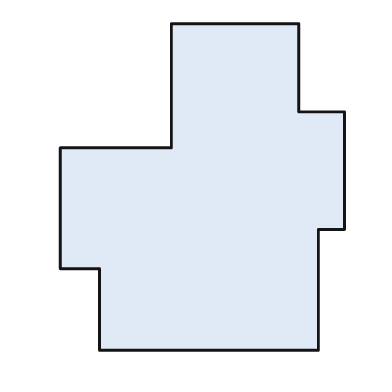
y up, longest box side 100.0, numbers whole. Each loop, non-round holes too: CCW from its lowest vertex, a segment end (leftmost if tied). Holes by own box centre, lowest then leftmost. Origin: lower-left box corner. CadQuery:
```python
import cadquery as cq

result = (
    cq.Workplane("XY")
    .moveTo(12.0, 0.0)
    .lineTo(79.0, 0.0)
    .lineTo(79.0, 37.0)
    .lineTo(87.0, 37.0)
    .lineTo(87.0, 73.0)
    .lineTo(73.0, 73.0)
    .lineTo(73.0, 100.0)
    .lineTo(34.0, 100.0)
    .lineTo(34.0, 62.0)
    .lineTo(0.0, 62.0)
    .lineTo(0.0, 25.0)
    .lineTo(12.0, 25.0)
    .close()
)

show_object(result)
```